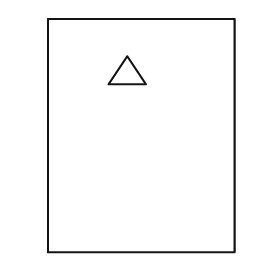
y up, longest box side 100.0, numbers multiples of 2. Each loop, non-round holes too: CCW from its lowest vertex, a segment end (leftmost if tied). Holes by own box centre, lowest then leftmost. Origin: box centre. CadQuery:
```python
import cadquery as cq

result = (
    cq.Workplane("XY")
    .moveTo(-40.0, -50.0)
    .lineTo(40.0, -50.0)
    .lineTo(40.0, 50.0)
    .lineTo(-40.0, 50.0)
    .close()
    .moveTo(-14.0, 22.0)
    .lineTo(2.0, 22.0)
    .lineTo(-6.0, 34.0)
    .close()
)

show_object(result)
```